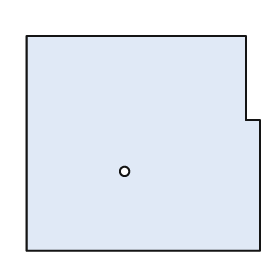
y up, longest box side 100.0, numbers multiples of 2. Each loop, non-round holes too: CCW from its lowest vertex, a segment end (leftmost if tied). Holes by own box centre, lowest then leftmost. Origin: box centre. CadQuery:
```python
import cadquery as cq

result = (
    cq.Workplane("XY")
    .moveTo(-50.0, -46.0)
    .lineTo(50.0, -46.0)
    .lineTo(50.0, 10.0)
    .lineTo(44.0, 10.0)
    .lineTo(44.0, 46.0)
    .lineTo(-50.0, 46.0)
    .close()
    .moveTo(-8.0, -12.0)
    .circle(2.0)
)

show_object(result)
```